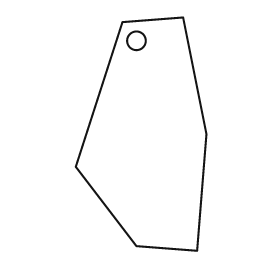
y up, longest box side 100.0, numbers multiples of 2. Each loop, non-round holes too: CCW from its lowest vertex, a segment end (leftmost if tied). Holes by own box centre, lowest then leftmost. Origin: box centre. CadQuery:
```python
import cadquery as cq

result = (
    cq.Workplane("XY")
    .moveTo(24.0, -50.0)
    .lineTo(28.0, 0.0)
    .lineTo(18.0, 50.0)
    .lineTo(-8.0, 48.0)
    .lineTo(-28.0, -14.0)
    .lineTo(-2.0, -48.0)
    .close()
    .moveTo(-2.0, 40.0)
    .circle(4.0)
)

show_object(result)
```